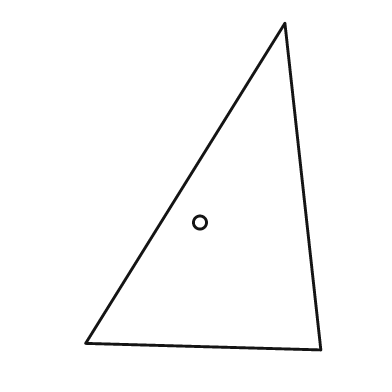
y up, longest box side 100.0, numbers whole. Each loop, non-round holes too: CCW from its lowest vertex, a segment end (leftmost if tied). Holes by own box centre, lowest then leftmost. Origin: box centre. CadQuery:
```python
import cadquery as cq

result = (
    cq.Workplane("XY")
    .moveTo(36.0, -50.0)
    .lineTo(25.0, 50.0)
    .lineTo(-36.0, -48.0)
    .close()
    .moveTo(-1.0, -11.0)
    .circle(2.0)
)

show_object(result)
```